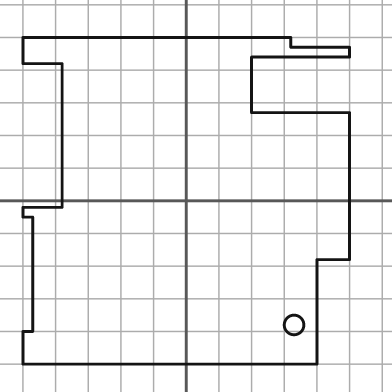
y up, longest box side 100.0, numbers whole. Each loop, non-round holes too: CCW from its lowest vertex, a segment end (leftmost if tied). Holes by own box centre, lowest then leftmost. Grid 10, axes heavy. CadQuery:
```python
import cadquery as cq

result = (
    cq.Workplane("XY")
    .moveTo(-50.0, -50.0)
    .lineTo(40.0, -50.0)
    .lineTo(40.0, -18.0)
    .lineTo(50.0, -18.0)
    .lineTo(50.0, 27.0)
    .lineTo(20.0, 27.0)
    .lineTo(20.0, 44.0)
    .lineTo(50.0, 44.0)
    .lineTo(50.0, 47.0)
    .lineTo(32.0, 47.0)
    .lineTo(32.0, 50.0)
    .lineTo(-50.0, 50.0)
    .lineTo(-50.0, 42.0)
    .lineTo(-38.0, 42.0)
    .lineTo(-38.0, -2.0)
    .lineTo(-50.0, -2.0)
    .lineTo(-50.0, -5.0)
    .lineTo(-47.0, -5.0)
    .lineTo(-47.0, -40.0)
    .lineTo(-50.0, -40.0)
    .close()
    .moveTo(33.0, -38.0)
    .circle(3.0)
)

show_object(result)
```